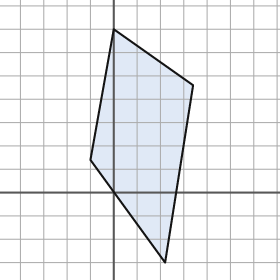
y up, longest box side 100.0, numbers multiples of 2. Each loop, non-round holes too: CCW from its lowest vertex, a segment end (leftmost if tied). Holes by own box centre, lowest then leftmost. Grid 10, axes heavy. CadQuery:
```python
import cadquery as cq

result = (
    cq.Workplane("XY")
    .moveTo(22.0, -30.0)
    .lineTo(34.0, 46.0)
    .lineTo(0.0, 70.0)
    .lineTo(-10.0, 14.0)
    .close()
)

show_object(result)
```